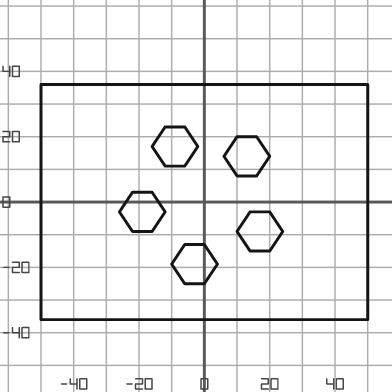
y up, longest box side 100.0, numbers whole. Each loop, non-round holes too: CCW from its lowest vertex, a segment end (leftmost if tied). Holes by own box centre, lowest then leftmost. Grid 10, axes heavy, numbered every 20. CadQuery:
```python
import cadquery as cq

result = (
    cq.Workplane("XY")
    .moveTo(-50.0, -36.0)
    .lineTo(50.0, -36.0)
    .lineTo(50.0, 36.0)
    .lineTo(-50.0, 36.0)
    .close()
    .moveTo(-6.0, -25.0)
    .lineTo(0.0, -25.0)
    .lineTo(4.0, -19.0)
    .lineTo(0.0, -13.0)
    .lineTo(-6.0, -13.0)
    .lineTo(-10.0, -19.0)
    .close()
    .moveTo(14.0, -15.0)
    .lineTo(20.0, -15.0)
    .lineTo(24.0, -9.0)
    .lineTo(20.0, -3.0)
    .lineTo(14.0, -3.0)
    .lineTo(10.0, -9.0)
    .close()
    .moveTo(-22.0, -9.0)
    .lineTo(-16.0, -9.0)
    .lineTo(-12.0, -3.0)
    .lineTo(-16.0, 3.0)
    .lineTo(-22.0, 3.0)
    .lineTo(-26.0, -3.0)
    .close()
    .moveTo(10.0, 8.0)
    .lineTo(16.0, 8.0)
    .lineTo(20.0, 14.0)
    .lineTo(16.0, 20.0)
    .lineTo(10.0, 20.0)
    .lineTo(6.0, 14.0)
    .close()
    .moveTo(-12.0, 11.0)
    .lineTo(-6.0, 11.0)
    .lineTo(-2.0, 17.0)
    .lineTo(-6.0, 23.0)
    .lineTo(-12.0, 23.0)
    .lineTo(-16.0, 17.0)
    .close()
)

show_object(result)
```